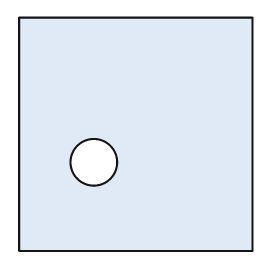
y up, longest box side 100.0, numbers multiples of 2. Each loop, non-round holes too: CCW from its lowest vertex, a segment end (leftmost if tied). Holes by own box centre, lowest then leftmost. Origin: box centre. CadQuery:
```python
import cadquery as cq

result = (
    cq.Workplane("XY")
    .moveTo(-50.0, -50.0)
    .lineTo(50.0, -50.0)
    .lineTo(50.0, 50.0)
    .lineTo(-50.0, 50.0)
    .close()
    .moveTo(-18.0, -12.0)
    .circle(10.0)
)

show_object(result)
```